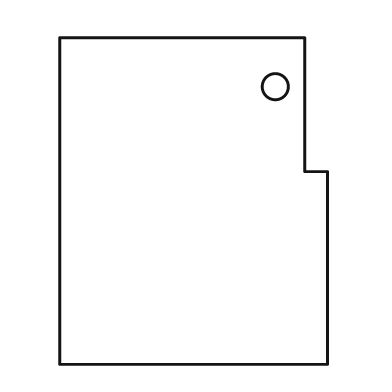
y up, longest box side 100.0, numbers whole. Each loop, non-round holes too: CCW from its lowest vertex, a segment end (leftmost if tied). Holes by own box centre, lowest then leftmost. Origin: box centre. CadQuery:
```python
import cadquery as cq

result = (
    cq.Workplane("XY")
    .moveTo(-41.0, -50.0)
    .lineTo(41.0, -50.0)
    .lineTo(41.0, 9.0)
    .lineTo(34.0, 9.0)
    .lineTo(34.0, 50.0)
    .lineTo(-41.0, 50.0)
    .close()
    .moveTo(25.0, 35.0)
    .circle(4.0)
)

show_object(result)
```